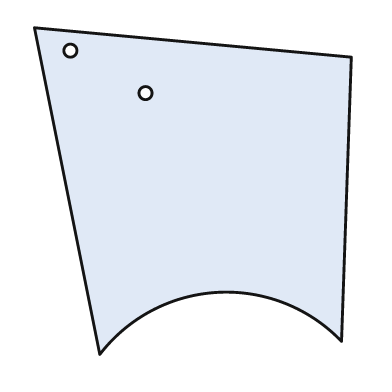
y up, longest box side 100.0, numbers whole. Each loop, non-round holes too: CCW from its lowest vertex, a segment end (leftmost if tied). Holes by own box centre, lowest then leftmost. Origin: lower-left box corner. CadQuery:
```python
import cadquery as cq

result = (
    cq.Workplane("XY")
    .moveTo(20.0, 0.0)
    .threePointArc((56.0, 19.0), (94.0, 4.0))
    .lineTo(97.0, 91.0)
    .lineTo(0.0, 100.0)
    .close()
    .moveTo(34.0, 80.0)
    .circle(2.0)
    .moveTo(11.0, 93.0)
    .circle(2.0)
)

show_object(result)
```